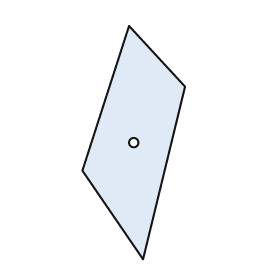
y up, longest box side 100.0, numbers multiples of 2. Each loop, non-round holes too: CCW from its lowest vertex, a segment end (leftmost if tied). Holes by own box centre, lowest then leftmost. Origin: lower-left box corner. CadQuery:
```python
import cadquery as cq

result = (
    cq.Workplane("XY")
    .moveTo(26.0, 0.0)
    .lineTo(44.0, 74.0)
    .lineTo(20.0, 100.0)
    .lineTo(0.0, 38.0)
    .close()
    .moveTo(22.0, 50.0)
    .circle(2.0)
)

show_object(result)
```